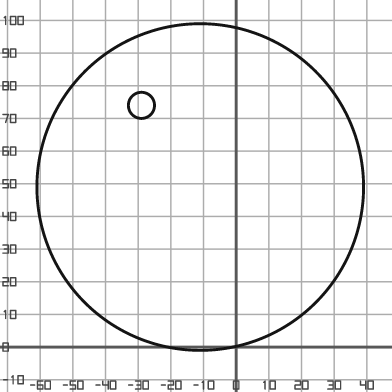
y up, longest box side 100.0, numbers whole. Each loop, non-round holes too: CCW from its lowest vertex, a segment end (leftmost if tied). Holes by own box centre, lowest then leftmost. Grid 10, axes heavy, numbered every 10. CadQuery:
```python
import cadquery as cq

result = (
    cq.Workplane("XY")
    .moveTo(-11.0, 49.0)
    .circle(50.0)
    .moveTo(-29.0, 74.0)
    .circle(4.0)
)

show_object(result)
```